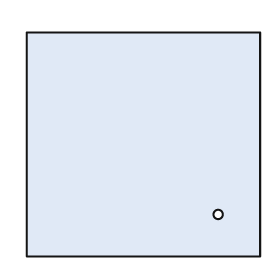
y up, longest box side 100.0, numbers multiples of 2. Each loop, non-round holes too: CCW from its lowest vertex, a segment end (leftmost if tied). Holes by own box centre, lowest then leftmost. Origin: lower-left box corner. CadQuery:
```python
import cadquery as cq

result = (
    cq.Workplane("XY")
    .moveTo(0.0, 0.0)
    .lineTo(100.0, 0.0)
    .lineTo(100.0, 96.0)
    .lineTo(0.0, 96.0)
    .close()
    .moveTo(82.0, 18.0)
    .circle(2.0)
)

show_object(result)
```